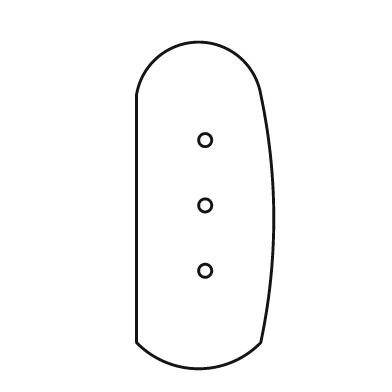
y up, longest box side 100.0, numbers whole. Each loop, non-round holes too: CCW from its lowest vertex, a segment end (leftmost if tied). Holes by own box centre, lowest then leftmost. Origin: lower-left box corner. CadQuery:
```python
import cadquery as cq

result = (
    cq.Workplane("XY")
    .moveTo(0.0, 8.0)
    .threePointArc((19.0, 0.0), (38.0, 8.0))
    .threePointArc((42.0, 46.0), (38.0, 84.0))
    .threePointArc((19.0, 100.0), (0.0, 84.0))
    .close()
    .moveTo(21.0, 30.0)
    .circle(2.0)
    .moveTo(21.0, 50.0)
    .circle(2.0)
    .moveTo(21.0, 70.0)
    .circle(2.0)
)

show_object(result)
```